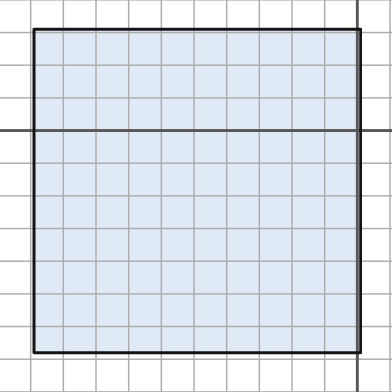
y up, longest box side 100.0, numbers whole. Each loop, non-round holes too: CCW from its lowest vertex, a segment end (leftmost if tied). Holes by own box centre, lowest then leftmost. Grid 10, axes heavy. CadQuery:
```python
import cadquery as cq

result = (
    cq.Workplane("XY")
    .moveTo(-99.0, -68.0)
    .lineTo(1.0, -68.0)
    .lineTo(1.0, 31.0)
    .lineTo(-99.0, 31.0)
    .close()
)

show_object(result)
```